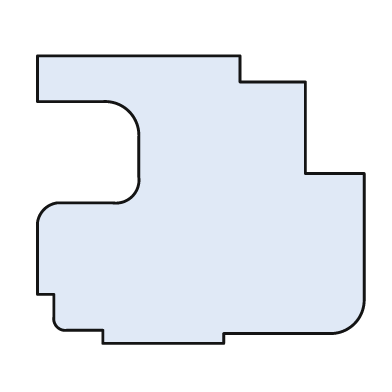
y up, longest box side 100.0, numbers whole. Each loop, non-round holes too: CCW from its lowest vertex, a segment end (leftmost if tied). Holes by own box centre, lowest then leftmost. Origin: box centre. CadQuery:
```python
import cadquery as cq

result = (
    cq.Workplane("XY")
    .moveTo(-30.0, -44.0)
    .lineTo(7.0, -44.0)
    .lineTo(7.0, -41.0)
    .lineTo(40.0, -41.0)
    .threePointArc((47.0, -38.0), (50.0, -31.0))
    .lineTo(50.0, 8.0)
    .lineTo(32.0, 8.0)
    .lineTo(32.0, 36.0)
    .lineTo(12.0, 36.0)
    .lineTo(12.0, 44.0)
    .lineTo(-50.0, 44.0)
    .lineTo(-50.0, 30.0)
    .lineTo(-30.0, 30.0)
    .threePointArc((-22.0, 27.0), (-19.0, 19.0))
    .lineTo(-19.0, 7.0)
    .threePointArc((-21.0, 1.0), (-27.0, -1.0))
    .lineTo(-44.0, -1.0)
    .threePointArc((-48.0, -3.0), (-50.0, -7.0))
    .lineTo(-50.0, -29.0)
    .lineTo(-45.0, -29.0)
    .lineTo(-45.0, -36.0)
    .threePointArc((-44.0, -39.0), (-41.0, -40.0))
    .lineTo(-30.0, -40.0)
    .close()
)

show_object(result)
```